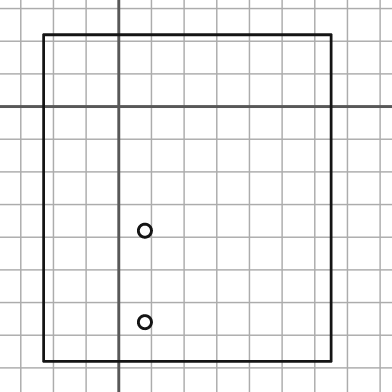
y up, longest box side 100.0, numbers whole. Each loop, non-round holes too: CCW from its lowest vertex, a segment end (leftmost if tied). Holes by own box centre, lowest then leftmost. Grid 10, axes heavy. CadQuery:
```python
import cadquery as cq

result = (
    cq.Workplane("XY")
    .moveTo(-23.0, -78.0)
    .lineTo(65.0, -78.0)
    .lineTo(65.0, 22.0)
    .lineTo(-23.0, 22.0)
    .close()
    .moveTo(8.0, -66.0)
    .circle(2.0)
    .moveTo(8.0, -38.0)
    .circle(2.0)
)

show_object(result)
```